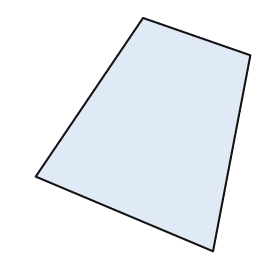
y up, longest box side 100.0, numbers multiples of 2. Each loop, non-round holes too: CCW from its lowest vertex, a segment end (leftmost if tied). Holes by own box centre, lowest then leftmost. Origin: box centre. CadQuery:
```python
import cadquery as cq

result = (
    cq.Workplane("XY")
    .moveTo(30.0, -50.0)
    .lineTo(46.0, 34.0)
    .lineTo(0.0, 50.0)
    .lineTo(-46.0, -18.0)
    .close()
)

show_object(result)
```